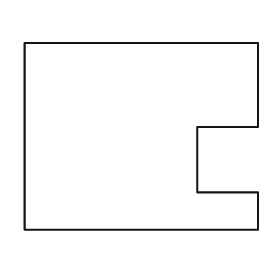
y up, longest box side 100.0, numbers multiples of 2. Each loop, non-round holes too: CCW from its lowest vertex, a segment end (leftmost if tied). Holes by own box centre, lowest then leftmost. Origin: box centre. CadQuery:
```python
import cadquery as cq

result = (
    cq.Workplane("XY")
    .moveTo(-50.0, -40.0)
    .lineTo(50.0, -40.0)
    .lineTo(50.0, -24.0)
    .lineTo(24.0, -24.0)
    .lineTo(24.0, 4.0)
    .lineTo(50.0, 4.0)
    .lineTo(50.0, 40.0)
    .lineTo(-50.0, 40.0)
    .close()
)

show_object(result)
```